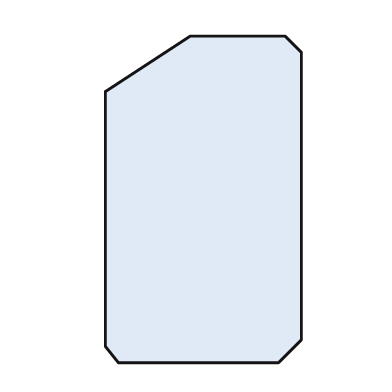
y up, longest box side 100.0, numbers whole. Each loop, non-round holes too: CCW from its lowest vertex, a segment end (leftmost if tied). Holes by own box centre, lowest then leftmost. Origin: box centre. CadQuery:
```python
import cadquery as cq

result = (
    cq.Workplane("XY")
    .moveTo(-26.0, -50.0)
    .lineTo(23.0, -50.0)
    .lineTo(30.0, -43.0)
    .lineTo(30.0, 45.0)
    .lineTo(25.0, 50.0)
    .lineTo(-4.0, 50.0)
    .lineTo(-30.0, 33.0)
    .lineTo(-30.0, -45.0)
    .close()
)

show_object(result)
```